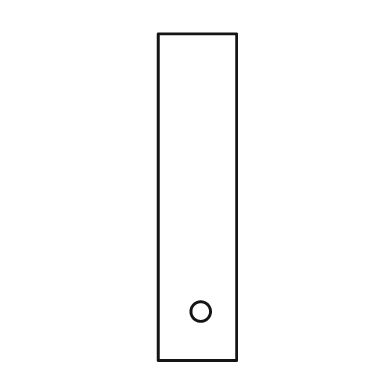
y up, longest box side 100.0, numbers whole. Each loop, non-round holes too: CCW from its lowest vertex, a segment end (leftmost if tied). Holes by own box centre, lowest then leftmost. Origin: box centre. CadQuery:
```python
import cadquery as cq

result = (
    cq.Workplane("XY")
    .moveTo(-12.0, -50.0)
    .lineTo(12.0, -50.0)
    .lineTo(12.0, 50.0)
    .lineTo(-12.0, 50.0)
    .close()
    .moveTo(1.0, -35.0)
    .circle(3.0)
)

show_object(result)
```